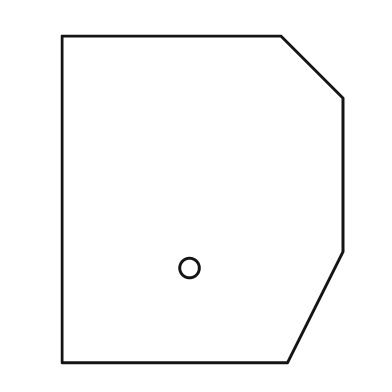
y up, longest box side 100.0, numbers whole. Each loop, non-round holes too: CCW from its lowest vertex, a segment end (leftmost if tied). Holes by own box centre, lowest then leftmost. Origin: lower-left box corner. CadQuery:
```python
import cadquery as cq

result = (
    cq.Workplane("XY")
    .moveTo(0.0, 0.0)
    .lineTo(69.0, 0.0)
    .lineTo(86.0, 34.0)
    .lineTo(86.0, 81.0)
    .lineTo(67.0, 100.0)
    .lineTo(0.0, 100.0)
    .close()
    .moveTo(39.0, 29.0)
    .circle(3.0)
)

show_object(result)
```